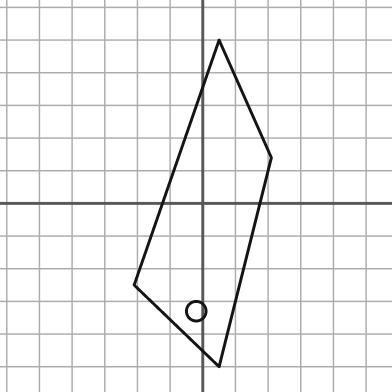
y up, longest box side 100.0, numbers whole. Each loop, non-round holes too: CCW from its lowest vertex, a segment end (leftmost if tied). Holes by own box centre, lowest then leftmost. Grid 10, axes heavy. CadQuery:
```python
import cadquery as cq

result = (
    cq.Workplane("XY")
    .moveTo(5.0, -50.0)
    .lineTo(21.0, 14.0)
    .lineTo(5.0, 50.0)
    .lineTo(-21.0, -25.0)
    .close()
    .moveTo(-2.0, -33.0)
    .circle(3.0)
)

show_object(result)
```